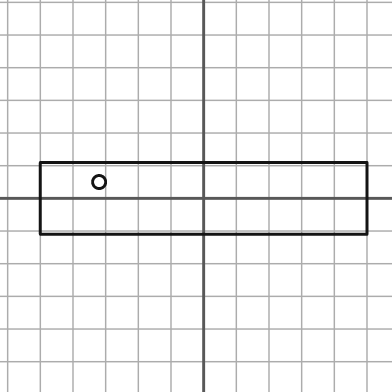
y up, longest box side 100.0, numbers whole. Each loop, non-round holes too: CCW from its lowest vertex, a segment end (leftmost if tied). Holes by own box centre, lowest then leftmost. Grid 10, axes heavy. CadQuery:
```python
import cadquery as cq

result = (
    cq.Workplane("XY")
    .moveTo(-50.0, -11.0)
    .lineTo(50.0, -11.0)
    .lineTo(50.0, 11.0)
    .lineTo(-50.0, 11.0)
    .close()
    .moveTo(-32.0, 5.0)
    .circle(2.0)
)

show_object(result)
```